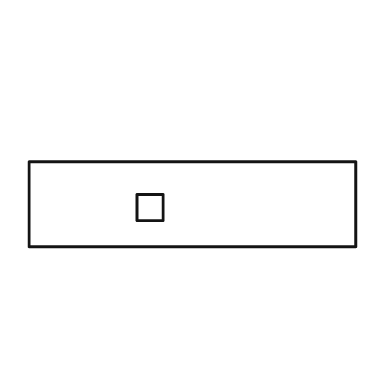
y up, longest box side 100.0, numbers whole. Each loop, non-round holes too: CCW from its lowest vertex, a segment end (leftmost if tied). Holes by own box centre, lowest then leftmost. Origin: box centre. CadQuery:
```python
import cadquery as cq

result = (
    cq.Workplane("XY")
    .moveTo(-50.0, -13.0)
    .lineTo(50.0, -13.0)
    .lineTo(50.0, 13.0)
    .lineTo(-50.0, 13.0)
    .close()
    .moveTo(-17.0, -5.0)
    .lineTo(-9.0, -5.0)
    .lineTo(-9.0, 3.0)
    .lineTo(-17.0, 3.0)
    .close()
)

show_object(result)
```